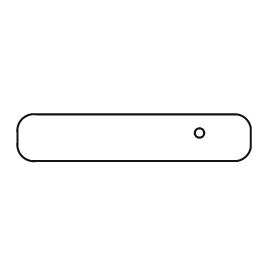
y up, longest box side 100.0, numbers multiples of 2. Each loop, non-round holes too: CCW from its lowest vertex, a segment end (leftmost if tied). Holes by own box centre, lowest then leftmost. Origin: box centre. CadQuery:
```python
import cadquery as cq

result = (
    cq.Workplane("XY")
    .moveTo(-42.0, -10.0)
    .lineTo(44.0, -10.0)
    .threePointArc((48.0, -8.0), (50.0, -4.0))
    .lineTo(50.0, 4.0)
    .threePointArc((48.0, 8.0), (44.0, 10.0))
    .lineTo(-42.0, 10.0)
    .threePointArc((-48.0, 8.0), (-50.0, 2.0))
    .lineTo(-50.0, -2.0)
    .threePointArc((-48.0, -8.0), (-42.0, -10.0))
    .close()
    .moveTo(28.0, 2.0)
    .circle(2.0)
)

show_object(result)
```